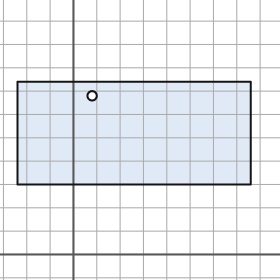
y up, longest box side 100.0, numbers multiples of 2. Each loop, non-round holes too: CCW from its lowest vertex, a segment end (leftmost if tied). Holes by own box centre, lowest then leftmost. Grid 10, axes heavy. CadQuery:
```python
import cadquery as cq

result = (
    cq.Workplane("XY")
    .moveTo(-24.0, 30.0)
    .lineTo(76.0, 30.0)
    .lineTo(76.0, 74.0)
    .lineTo(-24.0, 74.0)
    .close()
    .moveTo(8.0, 68.0)
    .circle(2.0)
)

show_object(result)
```